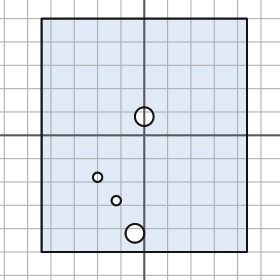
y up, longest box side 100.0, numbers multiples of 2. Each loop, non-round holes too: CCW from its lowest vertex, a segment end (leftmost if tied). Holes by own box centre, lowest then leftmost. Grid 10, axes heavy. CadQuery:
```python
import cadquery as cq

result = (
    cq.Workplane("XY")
    .moveTo(-44.0, -50.0)
    .lineTo(44.0, -50.0)
    .lineTo(44.0, 50.0)
    .lineTo(-44.0, 50.0)
    .close()
    .moveTo(-4.0, -42.0)
    .circle(4.0)
    .moveTo(-12.0, -28.0)
    .circle(2.0)
    .moveTo(-20.0, -18.0)
    .circle(2.0)
    .moveTo(0.0, 8.0)
    .circle(4.0)
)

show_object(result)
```